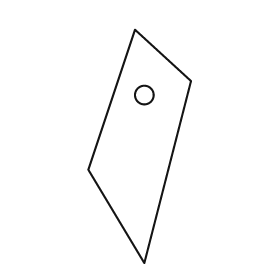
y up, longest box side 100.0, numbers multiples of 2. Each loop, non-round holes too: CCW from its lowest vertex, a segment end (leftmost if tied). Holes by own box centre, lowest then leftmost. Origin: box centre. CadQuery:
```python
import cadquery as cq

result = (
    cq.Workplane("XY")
    .moveTo(2.0, -50.0)
    .lineTo(22.0, 28.0)
    .lineTo(-2.0, 50.0)
    .lineTo(-22.0, -10.0)
    .close()
    .moveTo(2.0, 22.0)
    .circle(4.0)
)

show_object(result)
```